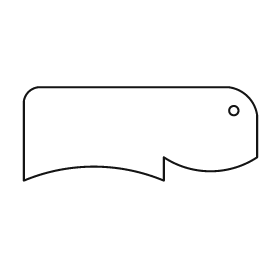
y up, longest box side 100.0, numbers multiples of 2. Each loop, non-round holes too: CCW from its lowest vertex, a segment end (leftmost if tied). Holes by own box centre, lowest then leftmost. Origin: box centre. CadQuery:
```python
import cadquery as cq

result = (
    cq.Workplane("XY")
    .moveTo(-50.0, -20.0)
    .threePointArc((-20.0, -14.0), (10.0, -20.0))
    .lineTo(10.0, -10.0)
    .threePointArc((30.0, -16.0), (50.0, -10.0))
    .lineTo(50.0, 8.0)
    .threePointArc((46.0, 16.0), (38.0, 20.0))
    .lineTo(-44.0, 20.0)
    .threePointArc((-48.0, 18.0), (-50.0, 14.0))
    .close()
    .moveTo(40.0, 10.0)
    .circle(2.0)
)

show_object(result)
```